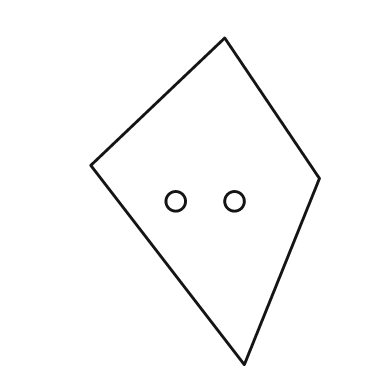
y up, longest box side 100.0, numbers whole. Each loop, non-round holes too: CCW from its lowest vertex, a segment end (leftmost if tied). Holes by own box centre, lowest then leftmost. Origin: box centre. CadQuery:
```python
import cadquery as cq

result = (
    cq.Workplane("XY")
    .moveTo(12.0, -50.0)
    .lineTo(35.0, 7.0)
    .lineTo(6.0, 50.0)
    .lineTo(-35.0, 11.0)
    .close()
    .moveTo(-9.0, 0.0)
    .circle(3.0)
    .moveTo(9.0, 0.0)
    .circle(3.0)
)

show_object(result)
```